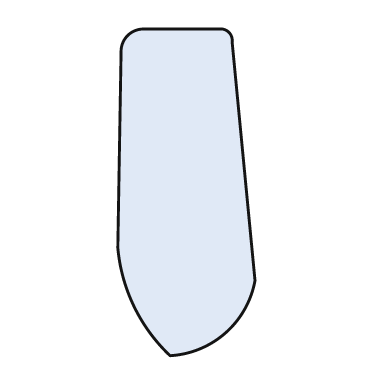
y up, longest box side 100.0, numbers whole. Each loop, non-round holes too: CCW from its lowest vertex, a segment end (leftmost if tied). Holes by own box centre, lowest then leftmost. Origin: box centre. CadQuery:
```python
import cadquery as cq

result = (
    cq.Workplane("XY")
    .moveTo(-5.0, -50.0)
    .threePointArc((12.0, -43.0), (21.0, -27.0))
    .lineTo(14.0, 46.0)
    .threePointArc((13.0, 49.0), (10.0, 50.0))
    .lineTo(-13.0, 50.0)
    .threePointArc((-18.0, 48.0), (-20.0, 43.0))
    .lineTo(-21.0, -17.0)
    .threePointArc((-16.0, -35.0), (-5.0, -50.0))
    .close()
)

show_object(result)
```